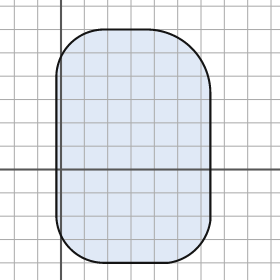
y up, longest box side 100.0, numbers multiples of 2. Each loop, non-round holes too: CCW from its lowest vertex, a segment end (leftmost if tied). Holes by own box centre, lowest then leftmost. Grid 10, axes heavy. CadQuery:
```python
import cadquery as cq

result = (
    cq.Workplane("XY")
    .moveTo(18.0, -40.0)
    .lineTo(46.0, -40.0)
    .threePointArc((58.0, -34.0), (64.0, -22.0))
    .lineTo(64.0, 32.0)
    .threePointArc((56.0, 52.0), (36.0, 60.0))
    .lineTo(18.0, 60.0)
    .threePointArc((4.0, 54.0), (-2.0, 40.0))
    .lineTo(-2.0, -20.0)
    .threePointArc((4.0, -34.0), (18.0, -40.0))
    .close()
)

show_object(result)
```